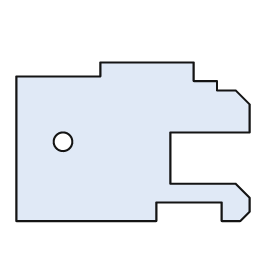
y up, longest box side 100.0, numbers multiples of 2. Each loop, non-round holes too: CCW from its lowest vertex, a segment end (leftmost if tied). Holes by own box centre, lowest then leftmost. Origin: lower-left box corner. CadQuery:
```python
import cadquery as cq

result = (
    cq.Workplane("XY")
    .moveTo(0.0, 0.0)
    .lineTo(60.0, 0.0)
    .lineTo(60.0, 8.0)
    .lineTo(88.0, 8.0)
    .lineTo(88.0, 0.0)
    .lineTo(96.0, 0.0)
    .lineTo(100.0, 4.0)
    .lineTo(100.0, 10.0)
    .lineTo(94.0, 16.0)
    .lineTo(66.0, 16.0)
    .lineTo(66.0, 38.0)
    .lineTo(100.0, 38.0)
    .lineTo(100.0, 50.0)
    .lineTo(94.0, 56.0)
    .lineTo(86.0, 56.0)
    .lineTo(86.0, 60.0)
    .lineTo(76.0, 60.0)
    .lineTo(76.0, 68.0)
    .lineTo(36.0, 68.0)
    .lineTo(36.0, 62.0)
    .lineTo(0.0, 62.0)
    .close()
    .moveTo(20.0, 34.0)
    .circle(4.0)
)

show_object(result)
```